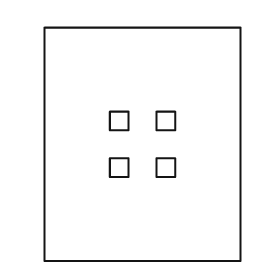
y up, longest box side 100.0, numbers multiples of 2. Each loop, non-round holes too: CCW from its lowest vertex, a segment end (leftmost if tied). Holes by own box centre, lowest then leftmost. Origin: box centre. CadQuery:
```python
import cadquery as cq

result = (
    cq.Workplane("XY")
    .moveTo(-42.0, -50.0)
    .lineTo(42.0, -50.0)
    .lineTo(42.0, 50.0)
    .lineTo(-42.0, 50.0)
    .close()
    .moveTo(-14.0, -14.0)
    .lineTo(-6.0, -14.0)
    .lineTo(-6.0, -6.0)
    .lineTo(-14.0, -6.0)
    .close()
    .moveTo(6.0, -14.0)
    .lineTo(14.0, -14.0)
    .lineTo(14.0, -6.0)
    .lineTo(6.0, -6.0)
    .close()
    .moveTo(-14.0, 6.0)
    .lineTo(-6.0, 6.0)
    .lineTo(-6.0, 14.0)
    .lineTo(-14.0, 14.0)
    .close()
    .moveTo(6.0, 6.0)
    .lineTo(14.0, 6.0)
    .lineTo(14.0, 14.0)
    .lineTo(6.0, 14.0)
    .close()
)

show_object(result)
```